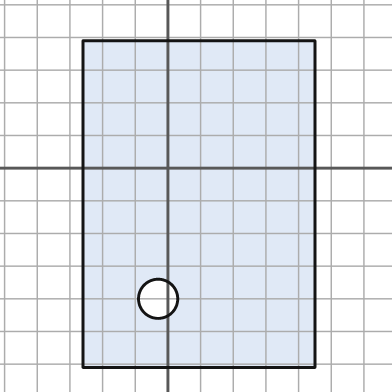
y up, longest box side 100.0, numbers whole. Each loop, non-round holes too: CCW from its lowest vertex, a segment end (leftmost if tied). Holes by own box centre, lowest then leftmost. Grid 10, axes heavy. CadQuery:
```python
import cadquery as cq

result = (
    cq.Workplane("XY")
    .moveTo(-26.0, -61.0)
    .lineTo(45.0, -61.0)
    .lineTo(45.0, 39.0)
    .lineTo(-26.0, 39.0)
    .close()
    .moveTo(-3.0, -40.0)
    .circle(6.0)
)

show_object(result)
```